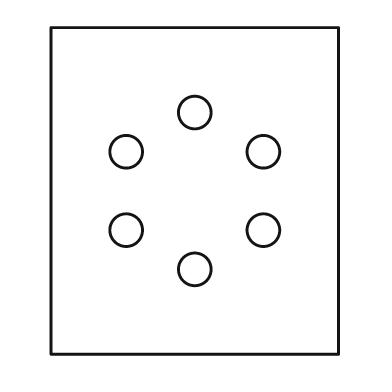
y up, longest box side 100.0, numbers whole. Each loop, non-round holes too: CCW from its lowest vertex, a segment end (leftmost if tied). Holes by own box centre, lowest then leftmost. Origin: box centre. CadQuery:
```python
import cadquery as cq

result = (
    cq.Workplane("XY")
    .moveTo(-44.0, -50.0)
    .lineTo(44.0, -50.0)
    .lineTo(44.0, 50.0)
    .lineTo(-44.0, 50.0)
    .close()
    .moveTo(0.0, -24.0)
    .circle(5.0)
    .moveTo(-21.0, -12.0)
    .circle(5.0)
    .moveTo(21.0, -12.0)
    .circle(5.0)
    .moveTo(-21.0, 12.0)
    .circle(5.0)
    .moveTo(21.0, 12.0)
    .circle(5.0)
    .moveTo(0.0, 24.0)
    .circle(5.0)
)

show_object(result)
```